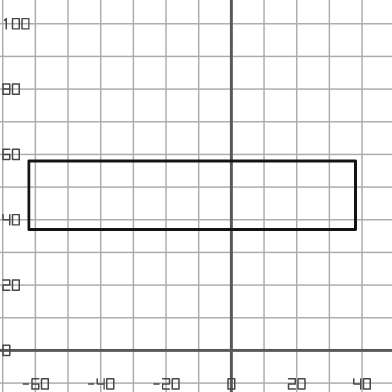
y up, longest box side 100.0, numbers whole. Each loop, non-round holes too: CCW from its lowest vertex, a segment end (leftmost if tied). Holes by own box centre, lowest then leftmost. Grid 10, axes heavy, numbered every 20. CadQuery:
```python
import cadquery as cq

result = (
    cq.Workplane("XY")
    .moveTo(-62.0, 37.0)
    .lineTo(38.0, 37.0)
    .lineTo(38.0, 58.0)
    .lineTo(-62.0, 58.0)
    .close()
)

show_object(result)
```